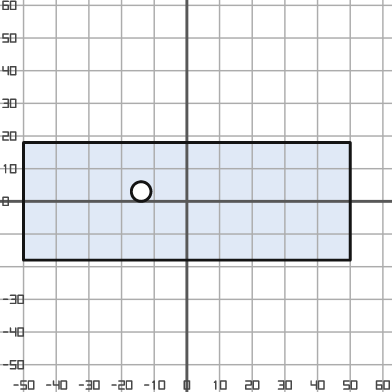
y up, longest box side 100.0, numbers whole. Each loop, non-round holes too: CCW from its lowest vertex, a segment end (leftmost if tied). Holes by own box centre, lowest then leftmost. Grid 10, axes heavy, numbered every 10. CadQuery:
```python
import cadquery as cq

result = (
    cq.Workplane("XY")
    .moveTo(-50.0, -18.0)
    .lineTo(50.0, -18.0)
    .lineTo(50.0, 18.0)
    .lineTo(-50.0, 18.0)
    .close()
    .moveTo(-14.0, 3.0)
    .circle(3.0)
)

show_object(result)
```